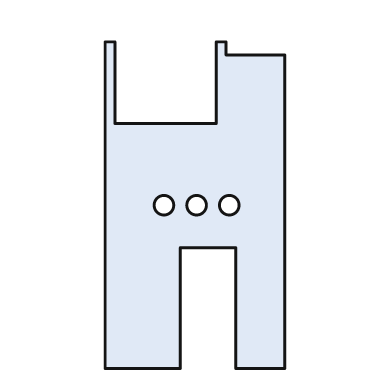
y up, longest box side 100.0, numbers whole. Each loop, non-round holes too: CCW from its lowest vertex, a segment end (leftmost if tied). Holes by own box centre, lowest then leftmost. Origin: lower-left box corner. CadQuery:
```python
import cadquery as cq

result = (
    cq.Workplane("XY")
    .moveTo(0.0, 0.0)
    .lineTo(23.0, 0.0)
    .lineTo(23.0, 37.0)
    .lineTo(40.0, 37.0)
    .lineTo(40.0, 0.0)
    .lineTo(55.0, 0.0)
    .lineTo(55.0, 96.0)
    .lineTo(37.0, 96.0)
    .lineTo(37.0, 100.0)
    .lineTo(34.0, 100.0)
    .lineTo(34.0, 75.0)
    .lineTo(3.0, 75.0)
    .lineTo(3.0, 100.0)
    .lineTo(0.0, 100.0)
    .close()
    .moveTo(18.0, 50.0)
    .circle(3.0)
    .moveTo(28.0, 50.0)
    .circle(3.0)
    .moveTo(38.0, 50.0)
    .circle(3.0)
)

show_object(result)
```